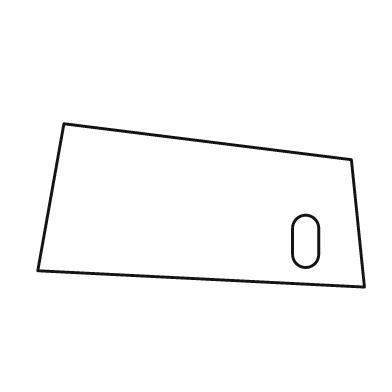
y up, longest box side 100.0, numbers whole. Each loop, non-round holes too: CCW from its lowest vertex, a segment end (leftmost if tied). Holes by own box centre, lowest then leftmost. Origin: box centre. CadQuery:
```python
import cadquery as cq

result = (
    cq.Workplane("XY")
    .moveTo(50.0, -25.0)
    .lineTo(46.0, 14.0)
    .lineTo(-42.0, 25.0)
    .lineTo(-50.0, -20.0)
    .close()
    .moveTo(28.0, -15.0)
    .threePointArc((32.0, -19.0), (36.0, -15.0))
    .lineTo(36.0, -7.0)
    .threePointArc((32.0, -3.0), (28.0, -7.0))
    .close()
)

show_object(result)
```